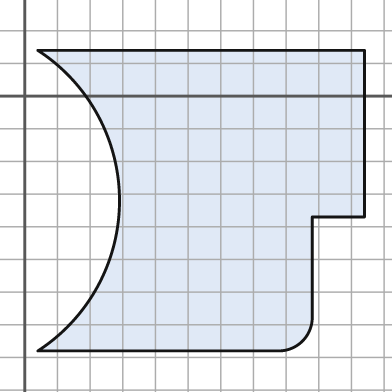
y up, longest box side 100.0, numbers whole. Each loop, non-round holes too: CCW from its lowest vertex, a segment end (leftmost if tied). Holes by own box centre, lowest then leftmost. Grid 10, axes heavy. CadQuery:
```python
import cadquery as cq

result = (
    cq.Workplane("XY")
    .moveTo(4.0, -78.0)
    .lineTo(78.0, -78.0)
    .threePointArc((85.0, -75.0), (88.0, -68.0))
    .lineTo(88.0, -37.0)
    .lineTo(104.0, -37.0)
    .lineTo(104.0, 14.0)
    .lineTo(4.0, 14.0)
    .threePointArc((29.0, -32.0), (4.0, -78.0))
    .close()
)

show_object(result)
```